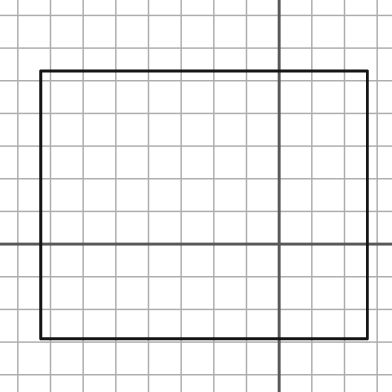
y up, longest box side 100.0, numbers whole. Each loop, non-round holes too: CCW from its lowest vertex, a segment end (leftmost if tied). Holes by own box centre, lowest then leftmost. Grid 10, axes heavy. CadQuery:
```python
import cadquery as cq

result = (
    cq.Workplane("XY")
    .moveTo(-73.0, -29.0)
    .lineTo(27.0, -29.0)
    .lineTo(27.0, 53.0)
    .lineTo(-73.0, 53.0)
    .close()
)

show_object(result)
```